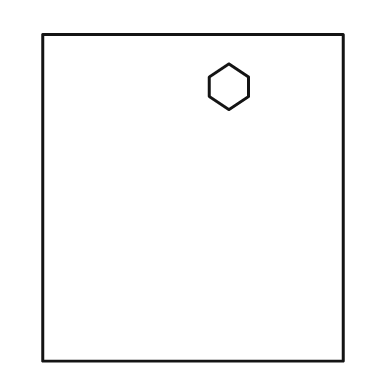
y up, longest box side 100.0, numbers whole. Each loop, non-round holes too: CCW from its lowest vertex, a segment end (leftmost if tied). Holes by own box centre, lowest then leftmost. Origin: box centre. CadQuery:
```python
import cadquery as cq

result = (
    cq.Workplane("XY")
    .moveTo(-46.0, -50.0)
    .lineTo(46.0, -50.0)
    .lineTo(46.0, 50.0)
    .lineTo(-46.0, 50.0)
    .close()
    .moveTo(11.0, 27.0)
    .lineTo(17.0, 31.0)
    .lineTo(17.0, 37.0)
    .lineTo(11.0, 41.0)
    .lineTo(5.0, 37.0)
    .lineTo(5.0, 31.0)
    .close()
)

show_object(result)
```